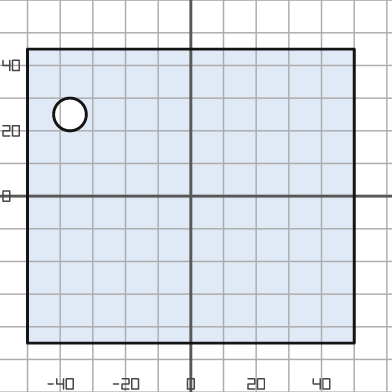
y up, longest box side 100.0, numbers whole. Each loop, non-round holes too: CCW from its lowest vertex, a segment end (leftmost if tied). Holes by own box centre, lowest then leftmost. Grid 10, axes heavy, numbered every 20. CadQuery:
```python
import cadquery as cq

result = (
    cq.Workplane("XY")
    .moveTo(-50.0, -45.0)
    .lineTo(50.0, -45.0)
    .lineTo(50.0, 45.0)
    .lineTo(-50.0, 45.0)
    .close()
    .moveTo(-37.0, 25.0)
    .circle(5.0)
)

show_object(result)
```